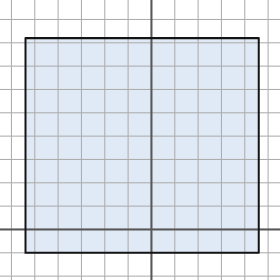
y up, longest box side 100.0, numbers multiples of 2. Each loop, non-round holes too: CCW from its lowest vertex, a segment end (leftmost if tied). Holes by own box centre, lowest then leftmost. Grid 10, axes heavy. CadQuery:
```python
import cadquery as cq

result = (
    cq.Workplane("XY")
    .moveTo(-54.0, -10.0)
    .lineTo(46.0, -10.0)
    .lineTo(46.0, 82.0)
    .lineTo(-54.0, 82.0)
    .close()
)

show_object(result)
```